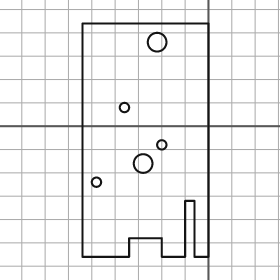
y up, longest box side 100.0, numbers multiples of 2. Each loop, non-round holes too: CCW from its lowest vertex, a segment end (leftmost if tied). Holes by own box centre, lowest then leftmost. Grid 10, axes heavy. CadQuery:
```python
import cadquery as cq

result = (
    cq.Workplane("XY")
    .moveTo(-54.0, -56.0)
    .lineTo(-34.0, -56.0)
    .lineTo(-34.0, -48.0)
    .lineTo(-20.0, -48.0)
    .lineTo(-20.0, -56.0)
    .lineTo(-10.0, -56.0)
    .lineTo(-10.0, -32.0)
    .lineTo(-6.0, -32.0)
    .lineTo(-6.0, -56.0)
    .lineTo(0.0, -56.0)
    .lineTo(0.0, 44.0)
    .lineTo(-54.0, 44.0)
    .close()
    .moveTo(-48.0, -24.0)
    .circle(2.0)
    .moveTo(-28.0, -16.0)
    .circle(4.0)
    .moveTo(-20.0, -8.0)
    .circle(2.0)
    .moveTo(-36.0, 8.0)
    .circle(2.0)
    .moveTo(-22.0, 36.0)
    .circle(4.0)
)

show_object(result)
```